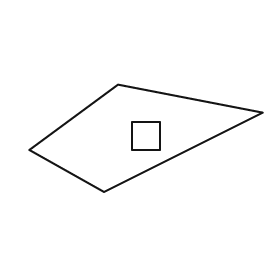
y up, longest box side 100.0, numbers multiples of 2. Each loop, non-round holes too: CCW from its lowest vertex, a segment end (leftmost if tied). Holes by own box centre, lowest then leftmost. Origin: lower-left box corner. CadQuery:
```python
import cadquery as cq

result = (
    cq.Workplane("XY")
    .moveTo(32.0, 0.0)
    .lineTo(100.0, 34.0)
    .lineTo(38.0, 46.0)
    .lineTo(0.0, 18.0)
    .close()
    .moveTo(44.0, 18.0)
    .lineTo(56.0, 18.0)
    .lineTo(56.0, 30.0)
    .lineTo(44.0, 30.0)
    .close()
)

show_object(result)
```